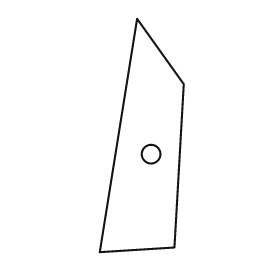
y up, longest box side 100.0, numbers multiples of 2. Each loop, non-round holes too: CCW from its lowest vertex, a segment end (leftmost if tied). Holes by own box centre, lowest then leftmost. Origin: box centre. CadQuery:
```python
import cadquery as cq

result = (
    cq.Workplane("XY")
    .moveTo(-18.0, -50.0)
    .lineTo(14.0, -48.0)
    .lineTo(18.0, 22.0)
    .lineTo(-2.0, 50.0)
    .close()
    .moveTo(4.0, -8.0)
    .circle(4.0)
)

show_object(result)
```